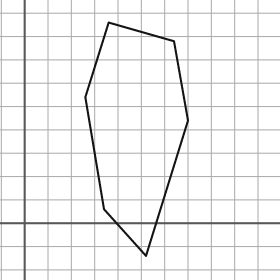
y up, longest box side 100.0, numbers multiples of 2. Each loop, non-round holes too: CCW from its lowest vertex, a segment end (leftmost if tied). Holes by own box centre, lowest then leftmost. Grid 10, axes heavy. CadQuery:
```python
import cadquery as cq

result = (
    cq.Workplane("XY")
    .moveTo(52.0, -14.0)
    .lineTo(70.0, 44.0)
    .lineTo(64.0, 78.0)
    .lineTo(36.0, 86.0)
    .lineTo(26.0, 54.0)
    .lineTo(34.0, 6.0)
    .close()
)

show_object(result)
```